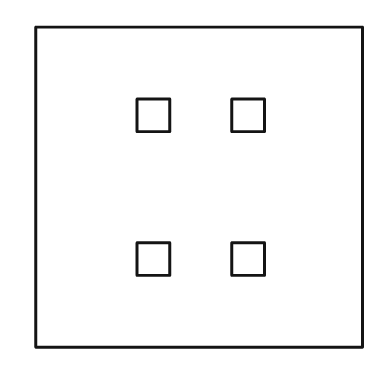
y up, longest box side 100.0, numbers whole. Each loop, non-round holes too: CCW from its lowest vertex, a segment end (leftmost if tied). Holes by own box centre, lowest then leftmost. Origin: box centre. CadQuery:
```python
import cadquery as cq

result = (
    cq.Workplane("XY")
    .moveTo(-50.0, -49.0)
    .lineTo(50.0, -49.0)
    .lineTo(50.0, 49.0)
    .lineTo(-50.0, 49.0)
    .close()
    .moveTo(-19.0, -27.0)
    .lineTo(-9.0, -27.0)
    .lineTo(-9.0, -17.0)
    .lineTo(-19.0, -17.0)
    .close()
    .moveTo(10.0, -27.0)
    .lineTo(20.0, -27.0)
    .lineTo(20.0, -17.0)
    .lineTo(10.0, -17.0)
    .close()
    .moveTo(-19.0, 17.0)
    .lineTo(-9.0, 17.0)
    .lineTo(-9.0, 27.0)
    .lineTo(-19.0, 27.0)
    .close()
    .moveTo(10.0, 17.0)
    .lineTo(20.0, 17.0)
    .lineTo(20.0, 27.0)
    .lineTo(10.0, 27.0)
    .close()
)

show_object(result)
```